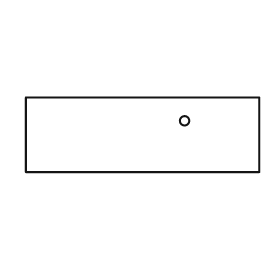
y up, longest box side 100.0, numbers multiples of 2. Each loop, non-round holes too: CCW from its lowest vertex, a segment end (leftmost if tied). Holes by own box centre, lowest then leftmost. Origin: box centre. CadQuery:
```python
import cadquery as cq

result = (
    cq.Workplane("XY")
    .moveTo(-50.0, -16.0)
    .lineTo(50.0, -16.0)
    .lineTo(50.0, 16.0)
    .lineTo(-50.0, 16.0)
    .close()
    .moveTo(18.0, 6.0)
    .circle(2.0)
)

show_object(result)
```